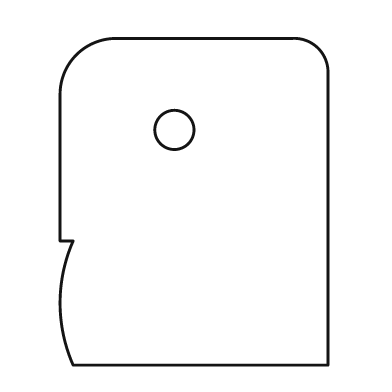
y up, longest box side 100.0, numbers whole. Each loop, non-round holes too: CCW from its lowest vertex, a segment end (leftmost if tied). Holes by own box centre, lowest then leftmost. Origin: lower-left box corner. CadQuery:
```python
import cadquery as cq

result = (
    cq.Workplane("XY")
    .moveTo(4.0, 0.0)
    .lineTo(82.0, 0.0)
    .lineTo(82.0, 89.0)
    .threePointArc((79.0, 97.0), (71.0, 100.0))
    .lineTo(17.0, 100.0)
    .threePointArc((5.0, 95.0), (0.0, 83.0))
    .lineTo(0.0, 38.0)
    .lineTo(4.0, 38.0)
    .threePointArc((0.0, 19.0), (4.0, 0.0))
    .close()
    .moveTo(35.0, 72.0)
    .circle(6.0)
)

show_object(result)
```